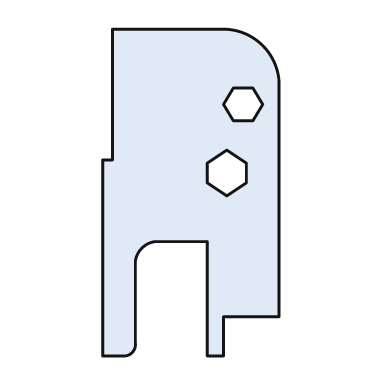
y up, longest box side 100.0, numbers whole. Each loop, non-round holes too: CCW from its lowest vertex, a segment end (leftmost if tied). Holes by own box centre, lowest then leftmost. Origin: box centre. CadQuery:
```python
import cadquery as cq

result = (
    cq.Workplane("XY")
    .moveTo(-27.0, -50.0)
    .lineTo(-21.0, -50.0)
    .threePointArc((-18.0, -49.0), (-17.0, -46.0))
    .lineTo(-17.0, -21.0)
    .threePointArc((-15.0, -17.0), (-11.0, -15.0))
    .lineTo(5.0, -15.0)
    .lineTo(5.0, -50.0)
    .lineTo(10.0, -50.0)
    .lineTo(10.0, -38.0)
    .lineTo(27.0, -38.0)
    .lineTo(27.0, 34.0)
    .threePointArc((22.0, 45.0), (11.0, 50.0))
    .lineTo(-24.0, 50.0)
    .lineTo(-24.0, 10.0)
    .lineTo(-27.0, 10.0)
    .close()
    .moveTo(11.0, -1.0)
    .lineTo(17.0, 3.0)
    .lineTo(17.0, 9.0)
    .lineTo(11.0, 13.0)
    .lineTo(5.0, 9.0)
    .lineTo(5.0, 3.0)
    .close()
    .moveTo(13.0, 22.0)
    .lineTo(19.0, 22.0)
    .lineTo(22.0, 27.0)
    .lineTo(19.0, 32.0)
    .lineTo(13.0, 32.0)
    .lineTo(10.0, 27.0)
    .close()
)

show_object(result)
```